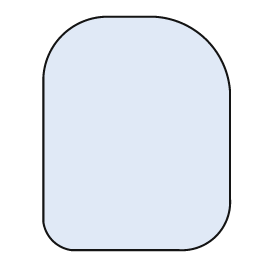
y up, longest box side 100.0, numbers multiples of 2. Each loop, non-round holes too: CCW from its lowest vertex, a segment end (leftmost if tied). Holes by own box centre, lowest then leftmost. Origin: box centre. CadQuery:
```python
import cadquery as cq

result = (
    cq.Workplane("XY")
    .moveTo(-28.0, -50.0)
    .lineTo(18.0, -50.0)
    .threePointArc((34.0, -44.0), (40.0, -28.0))
    .lineTo(40.0, 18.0)
    .threePointArc((30.0, 40.0), (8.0, 50.0))
    .lineTo(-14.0, 50.0)
    .threePointArc((-32.0, 42.0), (-40.0, 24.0))
    .lineTo(-40.0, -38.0)
    .threePointArc((-36.0, -46.0), (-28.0, -50.0))
    .close()
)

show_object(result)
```